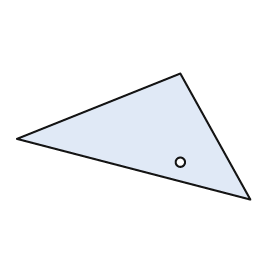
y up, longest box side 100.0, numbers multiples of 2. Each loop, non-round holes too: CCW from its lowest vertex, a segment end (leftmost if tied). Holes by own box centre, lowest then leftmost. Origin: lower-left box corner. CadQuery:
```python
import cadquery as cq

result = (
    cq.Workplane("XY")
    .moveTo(100.0, 0.0)
    .lineTo(70.0, 54.0)
    .lineTo(0.0, 26.0)
    .close()
    .moveTo(70.0, 16.0)
    .circle(2.0)
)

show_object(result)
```